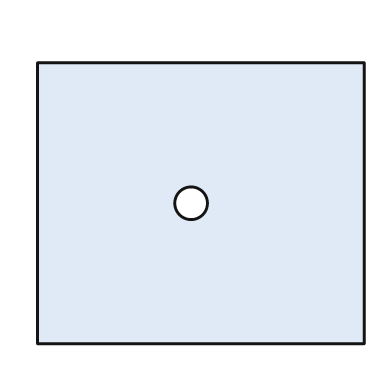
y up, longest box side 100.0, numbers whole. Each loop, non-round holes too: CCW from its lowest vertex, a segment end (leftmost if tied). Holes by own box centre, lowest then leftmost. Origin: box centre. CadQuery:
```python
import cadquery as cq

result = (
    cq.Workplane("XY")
    .moveTo(-50.0, -43.0)
    .lineTo(50.0, -43.0)
    .lineTo(50.0, 43.0)
    .lineTo(-50.0, 43.0)
    .close()
    .moveTo(-3.0, 0.0)
    .circle(5.0)
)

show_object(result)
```